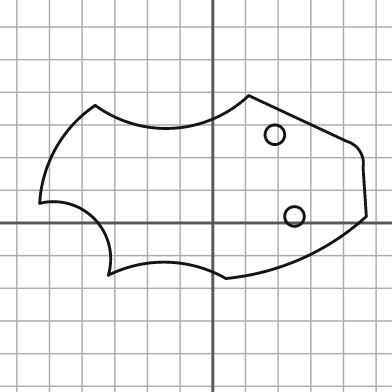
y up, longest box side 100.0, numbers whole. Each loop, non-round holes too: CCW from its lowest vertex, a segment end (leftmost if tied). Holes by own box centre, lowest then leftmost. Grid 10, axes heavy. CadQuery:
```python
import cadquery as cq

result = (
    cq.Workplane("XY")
    .moveTo(4.0, -17.0)
    .threePointArc((27.0, -11.0), (47.0, 2.0))
    .lineTo(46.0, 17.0)
    .threePointArc((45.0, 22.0), (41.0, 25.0))
    .lineTo(11.0, 39.0)
    .threePointArc((-12.0, 29.0), (-36.0, 36.0))
    .threePointArc((-48.0, 23.0), (-53.0, 6.0))
    .threePointArc((-36.0, 1.0), (-32.0, -16.0))
    .threePointArc((-14.0, -12.0), (4.0, -17.0))
    .close()
    .moveTo(25.0, 2.0)
    .circle(3.0)
    .moveTo(19.0, 27.0)
    .circle(3.0)
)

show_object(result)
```